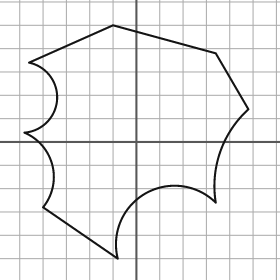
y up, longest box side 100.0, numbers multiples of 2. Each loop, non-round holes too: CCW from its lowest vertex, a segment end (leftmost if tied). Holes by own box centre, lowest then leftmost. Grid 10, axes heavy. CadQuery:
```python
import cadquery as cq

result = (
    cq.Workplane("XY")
    .moveTo(-8.0, -50.0)
    .threePointArc((4.0, -22.0), (34.0, -26.0))
    .threePointArc((36.0, -4.0), (48.0, 14.0))
    .lineTo(34.0, 38.0)
    .lineTo(-10.0, 50.0)
    .lineTo(-46.0, 34.0)
    .threePointArc((-34.0, 18.0), (-48.0, 4.0))
    .threePointArc((-36.0, -10.0), (-40.0, -28.0))
    .close()
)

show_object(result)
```